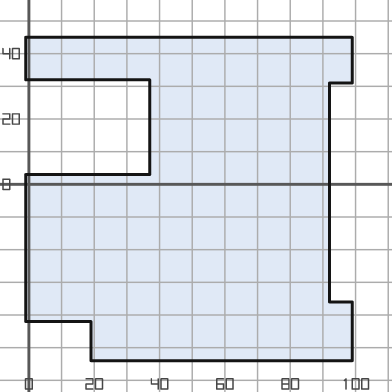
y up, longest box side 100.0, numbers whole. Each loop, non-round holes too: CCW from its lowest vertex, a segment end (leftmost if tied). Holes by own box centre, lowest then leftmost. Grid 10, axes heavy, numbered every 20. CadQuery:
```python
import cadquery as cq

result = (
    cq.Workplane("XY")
    .moveTo(19.0, -54.0)
    .lineTo(99.0, -54.0)
    .lineTo(99.0, -36.0)
    .lineTo(92.0, -36.0)
    .lineTo(92.0, 31.0)
    .lineTo(99.0, 31.0)
    .lineTo(99.0, 45.0)
    .lineTo(-1.0, 45.0)
    .lineTo(-1.0, 32.0)
    .lineTo(37.0, 32.0)
    .lineTo(37.0, 3.0)
    .lineTo(-1.0, 3.0)
    .lineTo(-1.0, -42.0)
    .lineTo(19.0, -42.0)
    .close()
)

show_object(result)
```